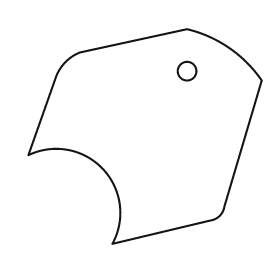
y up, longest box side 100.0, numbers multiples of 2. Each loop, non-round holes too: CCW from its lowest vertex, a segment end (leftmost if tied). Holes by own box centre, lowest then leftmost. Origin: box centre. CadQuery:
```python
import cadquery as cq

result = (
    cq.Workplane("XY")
    .moveTo(-14.0, -46.0)
    .lineTo(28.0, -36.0)
    .threePointArc((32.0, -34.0), (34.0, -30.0))
    .lineTo(50.0, 24.0)
    .threePointArc((36.0, 38.0), (18.0, 46.0))
    .lineTo(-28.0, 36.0)
    .threePointArc((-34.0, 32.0), (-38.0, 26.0))
    .lineTo(-50.0, -8.0)
    .threePointArc((-18.0, -14.0), (-14.0, -46.0))
    .close()
    .moveTo(18.0, 28.0)
    .circle(4.0)
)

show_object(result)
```